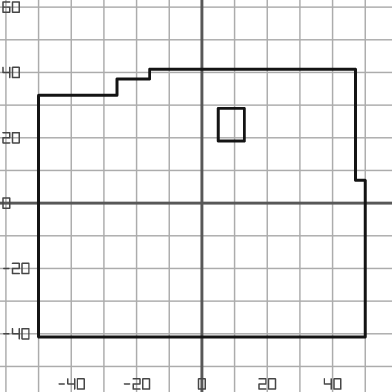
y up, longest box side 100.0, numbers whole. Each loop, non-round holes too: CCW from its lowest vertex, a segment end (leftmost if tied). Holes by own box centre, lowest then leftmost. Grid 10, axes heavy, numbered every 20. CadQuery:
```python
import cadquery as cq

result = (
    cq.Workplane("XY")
    .moveTo(-50.0, -41.0)
    .lineTo(50.0, -41.0)
    .lineTo(50.0, 7.0)
    .lineTo(47.0, 7.0)
    .lineTo(47.0, 41.0)
    .lineTo(-16.0, 41.0)
    .lineTo(-16.0, 38.0)
    .lineTo(-26.0, 38.0)
    .lineTo(-26.0, 33.0)
    .lineTo(-50.0, 33.0)
    .close()
    .moveTo(5.0, 19.0)
    .lineTo(13.0, 19.0)
    .lineTo(13.0, 29.0)
    .lineTo(5.0, 29.0)
    .close()
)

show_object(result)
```